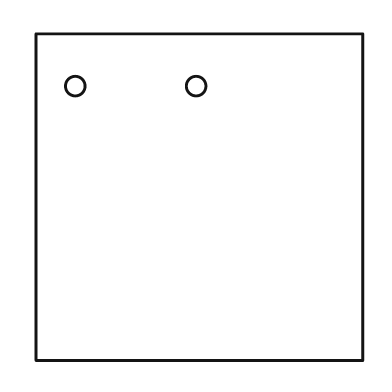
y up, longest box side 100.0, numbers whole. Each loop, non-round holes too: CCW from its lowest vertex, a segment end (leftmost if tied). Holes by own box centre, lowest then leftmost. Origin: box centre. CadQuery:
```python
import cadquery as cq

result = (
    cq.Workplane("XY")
    .moveTo(-50.0, -50.0)
    .lineTo(50.0, -50.0)
    .lineTo(50.0, 50.0)
    .lineTo(-50.0, 50.0)
    .close()
    .moveTo(-38.0, 34.0)
    .circle(3.0)
    .moveTo(-1.0, 34.0)
    .circle(3.0)
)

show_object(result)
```